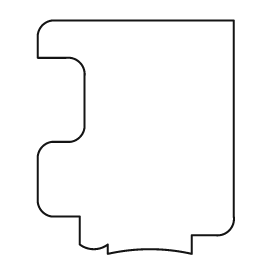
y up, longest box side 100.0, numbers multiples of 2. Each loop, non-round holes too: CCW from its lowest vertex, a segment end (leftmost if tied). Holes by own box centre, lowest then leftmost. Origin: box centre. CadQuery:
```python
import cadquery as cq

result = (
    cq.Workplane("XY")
    .moveTo(-12.0, -50.0)
    .threePointArc((6.0, -48.0), (24.0, -50.0))
    .lineTo(24.0, -42.0)
    .lineTo(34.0, -42.0)
    .threePointArc((40.0, -40.0), (42.0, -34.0))
    .lineTo(42.0, 50.0)
    .lineTo(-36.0, 50.0)
    .threePointArc((-40.0, 48.0), (-42.0, 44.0))
    .lineTo(-42.0, 34.0)
    .lineTo(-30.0, 34.0)
    .threePointArc((-24.0, 32.0), (-22.0, 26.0))
    .lineTo(-22.0, 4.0)
    .threePointArc((-24.0, 0.0), (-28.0, -2.0))
    .lineTo(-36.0, -2.0)
    .threePointArc((-40.0, -4.0), (-42.0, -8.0))
    .lineTo(-42.0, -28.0)
    .threePointArc((-40.0, -32.0), (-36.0, -34.0))
    .lineTo(-24.0, -34.0)
    .lineTo(-24.0, -46.0)
    .threePointArc((-18.0, -48.0), (-12.0, -46.0))
    .close()
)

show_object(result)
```